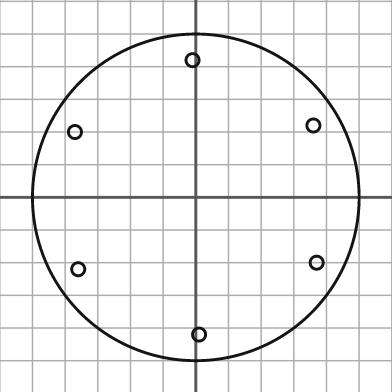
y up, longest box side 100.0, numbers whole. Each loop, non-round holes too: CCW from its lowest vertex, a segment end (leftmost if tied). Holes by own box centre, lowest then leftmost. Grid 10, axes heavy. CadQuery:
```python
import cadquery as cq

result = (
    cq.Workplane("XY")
    .moveTo(0.0, 0.0)
    .circle(50.0)
    .moveTo(1.0, -42.0)
    .circle(2.0)
    .moveTo(-36.0, -22.0)
    .circle(2.0)
    .moveTo(37.0, -20.0)
    .circle(2.0)
    .moveTo(-37.0, 20.0)
    .circle(2.0)
    .moveTo(36.0, 22.0)
    .circle(2.0)
    .moveTo(-1.0, 42.0)
    .circle(2.0)
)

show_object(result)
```